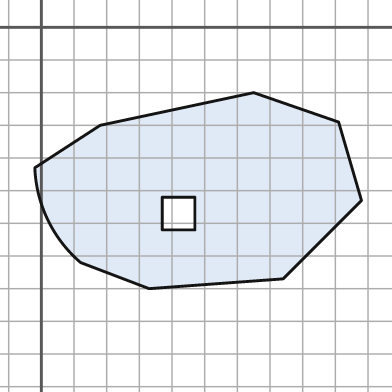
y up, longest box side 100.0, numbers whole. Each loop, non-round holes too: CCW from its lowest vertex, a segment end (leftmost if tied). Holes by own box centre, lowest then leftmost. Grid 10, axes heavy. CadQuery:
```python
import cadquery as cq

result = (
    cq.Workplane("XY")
    .moveTo(33.0, -80.0)
    .lineTo(74.0, -77.0)
    .lineTo(98.0, -53.0)
    .lineTo(91.0, -29.0)
    .lineTo(65.0, -20.0)
    .lineTo(18.0, -30.0)
    .lineTo(-2.0, -43.0)
    .threePointArc((2.0, -59.0), (12.0, -72.0))
    .close()
    .moveTo(37.0, -62.0)
    .lineTo(47.0, -62.0)
    .lineTo(47.0, -52.0)
    .lineTo(37.0, -52.0)
    .close()
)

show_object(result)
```